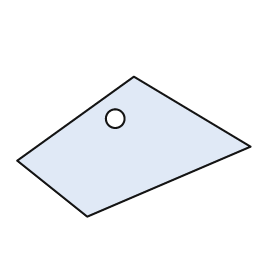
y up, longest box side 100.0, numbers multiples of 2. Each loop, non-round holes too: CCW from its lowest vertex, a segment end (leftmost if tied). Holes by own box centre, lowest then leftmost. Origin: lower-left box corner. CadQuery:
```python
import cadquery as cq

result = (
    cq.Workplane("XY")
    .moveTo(30.0, 0.0)
    .lineTo(100.0, 30.0)
    .lineTo(50.0, 60.0)
    .lineTo(0.0, 24.0)
    .close()
    .moveTo(42.0, 42.0)
    .circle(4.0)
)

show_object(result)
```